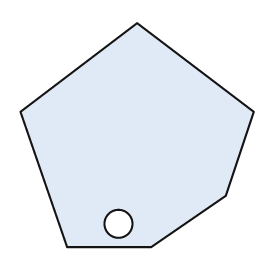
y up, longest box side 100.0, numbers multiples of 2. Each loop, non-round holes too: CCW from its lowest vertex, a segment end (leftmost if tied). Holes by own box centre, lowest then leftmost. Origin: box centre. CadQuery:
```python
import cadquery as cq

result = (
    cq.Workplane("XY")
    .moveTo(-30.0, -48.0)
    .lineTo(6.0, -48.0)
    .lineTo(38.0, -26.0)
    .lineTo(50.0, 10.0)
    .lineTo(0.0, 48.0)
    .lineTo(-50.0, 10.0)
    .close()
    .moveTo(-8.0, -38.0)
    .circle(6.0)
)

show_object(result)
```